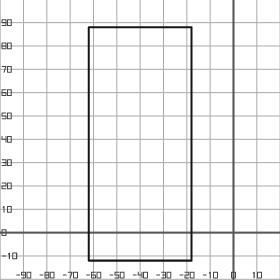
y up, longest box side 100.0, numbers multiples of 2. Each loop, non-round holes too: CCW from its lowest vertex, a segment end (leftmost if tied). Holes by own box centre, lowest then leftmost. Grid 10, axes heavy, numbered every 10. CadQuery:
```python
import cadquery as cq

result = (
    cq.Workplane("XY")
    .moveTo(-62.0, -12.0)
    .lineTo(-18.0, -12.0)
    .lineTo(-18.0, 88.0)
    .lineTo(-62.0, 88.0)
    .close()
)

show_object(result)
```